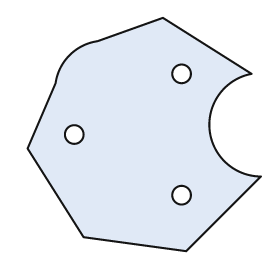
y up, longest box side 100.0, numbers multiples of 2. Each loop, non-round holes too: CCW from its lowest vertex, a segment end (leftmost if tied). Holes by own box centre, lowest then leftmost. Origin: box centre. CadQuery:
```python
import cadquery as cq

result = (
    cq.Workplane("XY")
    .moveTo(18.0, -50.0)
    .lineTo(50.0, -18.0)
    .threePointArc((28.0, 2.0), (46.0, 26.0))
    .lineTo(8.0, 50.0)
    .lineTo(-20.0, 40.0)
    .threePointArc((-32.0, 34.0), (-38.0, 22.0))
    .lineTo(-50.0, -6.0)
    .lineTo(-26.0, -44.0)
    .close()
    .moveTo(16.0, -26.0)
    .circle(4.0)
    .moveTo(-30.0, 0.0)
    .circle(4.0)
    .moveTo(16.0, 26.0)
    .circle(4.0)
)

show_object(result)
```